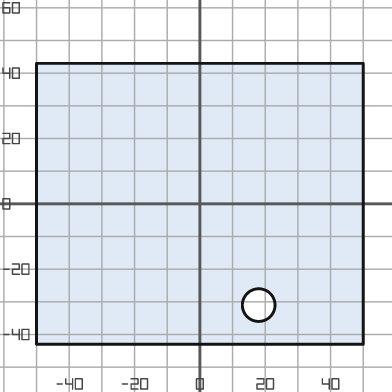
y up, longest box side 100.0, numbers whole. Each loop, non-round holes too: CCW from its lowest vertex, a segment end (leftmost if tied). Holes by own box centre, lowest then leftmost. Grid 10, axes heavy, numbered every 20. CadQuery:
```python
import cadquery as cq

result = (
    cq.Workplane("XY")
    .moveTo(-50.0, -43.0)
    .lineTo(50.0, -43.0)
    .lineTo(50.0, 43.0)
    .lineTo(-50.0, 43.0)
    .close()
    .moveTo(18.0, -31.0)
    .circle(5.0)
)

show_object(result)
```